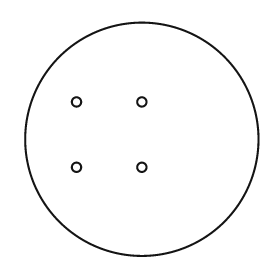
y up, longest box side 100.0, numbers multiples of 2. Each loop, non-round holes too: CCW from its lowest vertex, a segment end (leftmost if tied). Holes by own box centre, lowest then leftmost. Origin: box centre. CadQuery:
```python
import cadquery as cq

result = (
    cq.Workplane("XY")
    .moveTo(0.0, 0.0)
    .circle(50.0)
    .moveTo(-28.0, -12.0)
    .circle(2.0)
    .moveTo(0.0, -12.0)
    .circle(2.0)
    .moveTo(-28.0, 16.0)
    .circle(2.0)
    .moveTo(0.0, 16.0)
    .circle(2.0)
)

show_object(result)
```